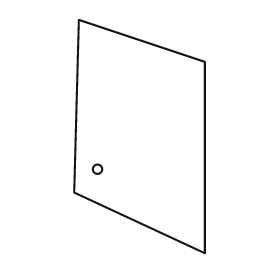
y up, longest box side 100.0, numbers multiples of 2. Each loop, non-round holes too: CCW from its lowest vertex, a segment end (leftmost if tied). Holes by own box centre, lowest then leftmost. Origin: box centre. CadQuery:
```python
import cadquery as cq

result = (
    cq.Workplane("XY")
    .moveTo(28.0, -50.0)
    .lineTo(28.0, 32.0)
    .lineTo(-26.0, 50.0)
    .lineTo(-28.0, -24.0)
    .close()
    .moveTo(-18.0, -14.0)
    .circle(2.0)
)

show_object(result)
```